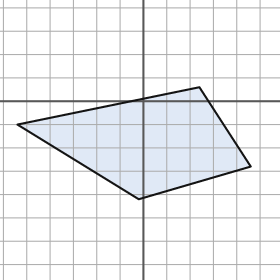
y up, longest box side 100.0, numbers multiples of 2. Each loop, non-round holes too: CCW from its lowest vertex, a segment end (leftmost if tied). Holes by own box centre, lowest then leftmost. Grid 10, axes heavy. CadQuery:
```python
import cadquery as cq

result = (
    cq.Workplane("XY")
    .moveTo(-2.0, -42.0)
    .lineTo(46.0, -28.0)
    .lineTo(24.0, 6.0)
    .lineTo(-54.0, -10.0)
    .close()
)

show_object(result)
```